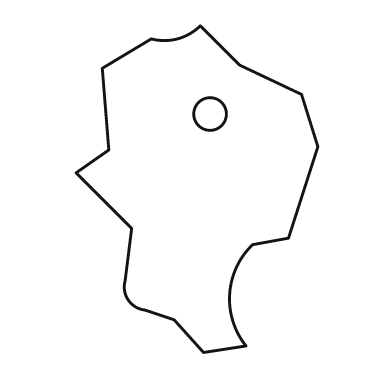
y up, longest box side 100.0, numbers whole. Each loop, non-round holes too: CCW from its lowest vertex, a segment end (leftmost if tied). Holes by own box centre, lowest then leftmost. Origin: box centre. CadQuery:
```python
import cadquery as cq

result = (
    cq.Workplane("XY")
    .moveTo(2.0, -50.0)
    .lineTo(15.0, -48.0)
    .threePointArc((10.0, -32.0), (17.0, -17.0))
    .lineTo(28.0, -15.0)
    .lineTo(37.0, 13.0)
    .lineTo(32.0, 29.0)
    .lineTo(13.0, 38.0)
    .lineTo(1.0, 50.0)
    .threePointArc((-6.0, 46.0), (-14.0, 46.0))
    .lineTo(-29.0, 37.0)
    .lineTo(-27.0, 12.0)
    .lineTo(-37.0, 5.0)
    .lineTo(-20.0, -12.0)
    .lineTo(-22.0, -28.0)
    .threePointArc((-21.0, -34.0), (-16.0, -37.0))
    .lineTo(-7.0, -40.0)
    .close()
    .moveTo(4.0, 23.0)
    .circle(5.0)
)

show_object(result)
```